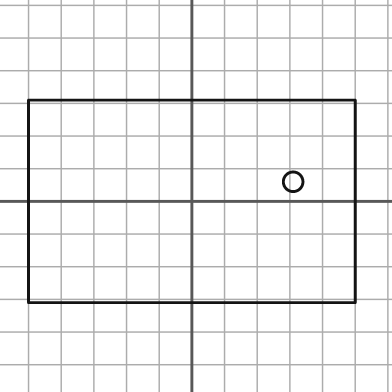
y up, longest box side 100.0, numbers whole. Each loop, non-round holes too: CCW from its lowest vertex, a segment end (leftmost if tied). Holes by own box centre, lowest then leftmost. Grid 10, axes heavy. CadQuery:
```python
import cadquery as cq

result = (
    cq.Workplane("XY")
    .moveTo(-50.0, -31.0)
    .lineTo(50.0, -31.0)
    .lineTo(50.0, 31.0)
    .lineTo(-50.0, 31.0)
    .close()
    .moveTo(31.0, 6.0)
    .circle(3.0)
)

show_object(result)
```